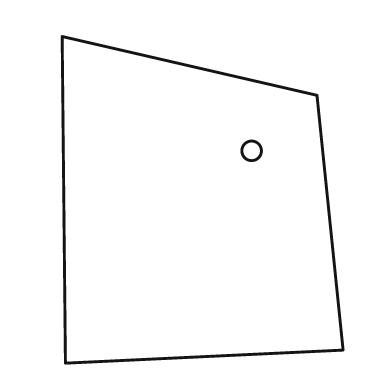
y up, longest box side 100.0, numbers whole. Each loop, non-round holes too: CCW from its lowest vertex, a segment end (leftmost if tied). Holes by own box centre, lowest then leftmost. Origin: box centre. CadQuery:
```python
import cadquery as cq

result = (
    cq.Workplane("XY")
    .moveTo(-42.0, -50.0)
    .lineTo(43.0, -46.0)
    .lineTo(35.0, 32.0)
    .lineTo(-43.0, 50.0)
    .close()
    .moveTo(15.0, 15.0)
    .circle(3.0)
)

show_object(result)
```